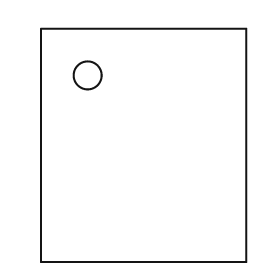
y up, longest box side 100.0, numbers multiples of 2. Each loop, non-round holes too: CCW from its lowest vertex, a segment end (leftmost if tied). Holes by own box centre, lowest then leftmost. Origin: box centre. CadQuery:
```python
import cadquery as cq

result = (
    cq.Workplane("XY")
    .moveTo(-44.0, -50.0)
    .lineTo(44.0, -50.0)
    .lineTo(44.0, 50.0)
    .lineTo(-44.0, 50.0)
    .close()
    .moveTo(-24.0, 30.0)
    .circle(6.0)
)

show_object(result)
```